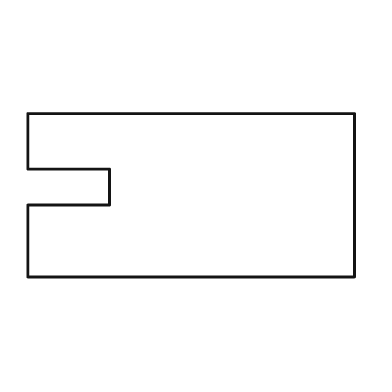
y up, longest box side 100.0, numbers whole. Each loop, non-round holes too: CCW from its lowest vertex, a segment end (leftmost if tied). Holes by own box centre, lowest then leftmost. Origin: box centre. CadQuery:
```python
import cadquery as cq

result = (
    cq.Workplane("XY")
    .moveTo(-50.0, -25.0)
    .lineTo(50.0, -25.0)
    .lineTo(50.0, 25.0)
    .lineTo(-50.0, 25.0)
    .lineTo(-50.0, 8.0)
    .lineTo(-25.0, 8.0)
    .lineTo(-25.0, -3.0)
    .lineTo(-50.0, -3.0)
    .close()
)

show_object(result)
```